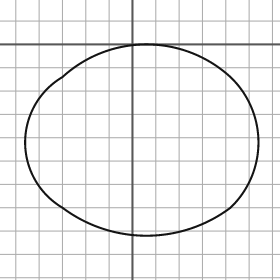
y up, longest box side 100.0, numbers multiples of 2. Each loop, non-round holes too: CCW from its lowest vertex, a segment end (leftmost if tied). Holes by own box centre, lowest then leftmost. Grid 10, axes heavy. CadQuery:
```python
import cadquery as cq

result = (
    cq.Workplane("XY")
    .moveTo(-30.0, -70.0)
    .threePointArc((6.0, -82.0), (42.0, -70.0))
    .threePointArc((54.0, -42.0), (42.0, -14.0))
    .threePointArc((6.0, 0.0), (-30.0, -14.0))
    .threePointArc((-46.0, -42.0), (-30.0, -70.0))
    .close()
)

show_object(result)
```